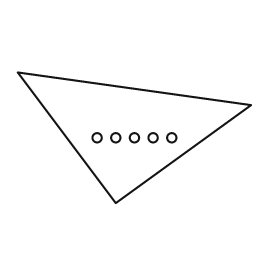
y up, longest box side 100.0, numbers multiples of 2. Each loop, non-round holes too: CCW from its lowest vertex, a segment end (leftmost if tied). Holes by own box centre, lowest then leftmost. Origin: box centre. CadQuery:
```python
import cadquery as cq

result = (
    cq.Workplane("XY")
    .moveTo(-8.0, -28.0)
    .lineTo(50.0, 14.0)
    .lineTo(-50.0, 28.0)
    .close()
    .moveTo(-16.0, 0.0)
    .circle(2.0)
    .moveTo(-8.0, 0.0)
    .circle(2.0)
    .moveTo(0.0, 0.0)
    .circle(2.0)
    .moveTo(8.0, 0.0)
    .circle(2.0)
    .moveTo(16.0, 0.0)
    .circle(2.0)
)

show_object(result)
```